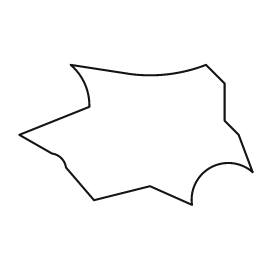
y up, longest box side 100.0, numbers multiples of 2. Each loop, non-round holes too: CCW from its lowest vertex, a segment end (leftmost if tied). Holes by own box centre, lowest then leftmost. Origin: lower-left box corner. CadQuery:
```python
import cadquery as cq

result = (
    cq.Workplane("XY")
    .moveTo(74.0, 0.0)
    .threePointArc((82.0, 16.0), (100.0, 14.0))
    .lineTo(94.0, 30.0)
    .lineTo(88.0, 36.0)
    .lineTo(88.0, 52.0)
    .lineTo(80.0, 60.0)
    .threePointArc((64.0, 56.0), (48.0, 56.0))
    .lineTo(22.0, 60.0)
    .threePointArc((28.0, 52.0), (30.0, 42.0))
    .lineTo(0.0, 30.0)
    .lineTo(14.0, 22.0)
    .threePointArc((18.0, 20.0), (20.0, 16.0))
    .lineTo(32.0, 2.0)
    .lineTo(56.0, 8.0)
    .close()
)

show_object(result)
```